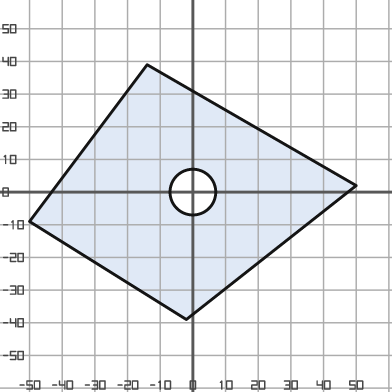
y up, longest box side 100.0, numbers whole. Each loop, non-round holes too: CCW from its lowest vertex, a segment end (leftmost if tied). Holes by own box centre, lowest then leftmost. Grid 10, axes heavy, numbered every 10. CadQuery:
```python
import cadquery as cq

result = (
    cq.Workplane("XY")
    .moveTo(-2.0, -39.0)
    .lineTo(50.0, 2.0)
    .lineTo(-14.0, 39.0)
    .lineTo(-50.0, -9.0)
    .close()
    .moveTo(0.0, 0.0)
    .circle(7.0)
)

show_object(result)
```